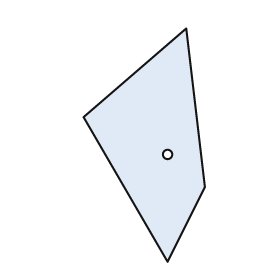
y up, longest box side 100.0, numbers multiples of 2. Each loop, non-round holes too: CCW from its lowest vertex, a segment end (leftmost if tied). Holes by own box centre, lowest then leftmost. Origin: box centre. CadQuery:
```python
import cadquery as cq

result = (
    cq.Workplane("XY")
    .moveTo(10.0, -50.0)
    .lineTo(26.0, -18.0)
    .lineTo(18.0, 50.0)
    .lineTo(-26.0, 12.0)
    .close()
    .moveTo(10.0, -4.0)
    .circle(2.0)
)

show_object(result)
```